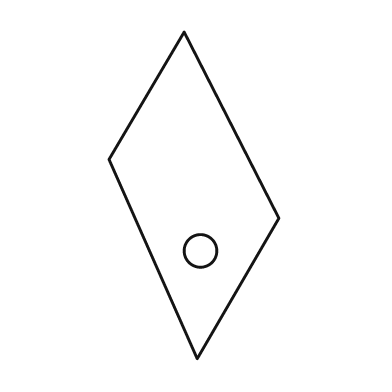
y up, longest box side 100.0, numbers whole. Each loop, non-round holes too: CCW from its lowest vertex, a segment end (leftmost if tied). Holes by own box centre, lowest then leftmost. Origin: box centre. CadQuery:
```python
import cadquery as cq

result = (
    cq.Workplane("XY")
    .moveTo(1.0, -50.0)
    .lineTo(26.0, -7.0)
    .lineTo(-3.0, 50.0)
    .lineTo(-26.0, 11.0)
    .close()
    .moveTo(2.0, -17.0)
    .circle(5.0)
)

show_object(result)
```